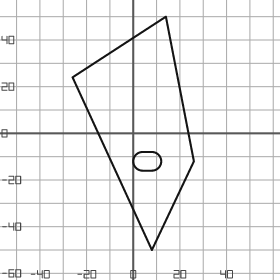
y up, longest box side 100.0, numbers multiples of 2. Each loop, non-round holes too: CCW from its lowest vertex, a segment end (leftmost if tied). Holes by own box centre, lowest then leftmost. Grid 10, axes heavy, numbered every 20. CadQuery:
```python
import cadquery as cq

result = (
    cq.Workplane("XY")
    .moveTo(8.0, -50.0)
    .lineTo(26.0, -12.0)
    .lineTo(14.0, 50.0)
    .lineTo(-26.0, 24.0)
    .close()
    .moveTo(4.0, -16.0)
    .lineTo(8.0, -16.0)
    .threePointArc((12.0, -12.0), (8.0, -8.0))
    .lineTo(4.0, -8.0)
    .threePointArc((0.0, -12.0), (4.0, -16.0))
    .close()
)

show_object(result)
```